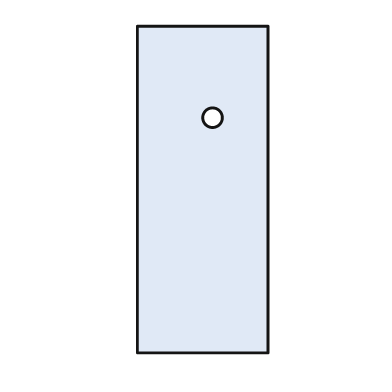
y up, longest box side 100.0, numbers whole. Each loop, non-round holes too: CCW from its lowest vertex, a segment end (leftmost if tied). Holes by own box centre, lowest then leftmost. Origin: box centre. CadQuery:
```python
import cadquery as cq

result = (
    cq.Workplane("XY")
    .moveTo(-20.0, -50.0)
    .lineTo(20.0, -50.0)
    .lineTo(20.0, 50.0)
    .lineTo(-20.0, 50.0)
    .close()
    .moveTo(3.0, 22.0)
    .circle(3.0)
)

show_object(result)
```